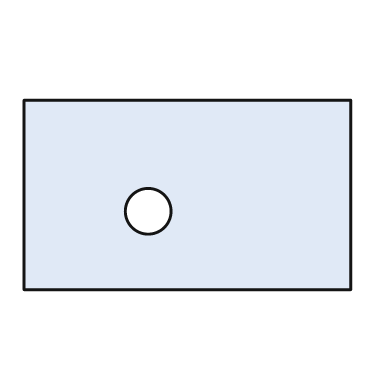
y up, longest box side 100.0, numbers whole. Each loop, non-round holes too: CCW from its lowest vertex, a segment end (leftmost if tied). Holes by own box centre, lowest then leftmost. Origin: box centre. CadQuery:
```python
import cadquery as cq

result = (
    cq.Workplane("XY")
    .moveTo(-50.0, -29.0)
    .lineTo(50.0, -29.0)
    .lineTo(50.0, 29.0)
    .lineTo(-50.0, 29.0)
    .close()
    .moveTo(-12.0, -5.0)
    .circle(7.0)
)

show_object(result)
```